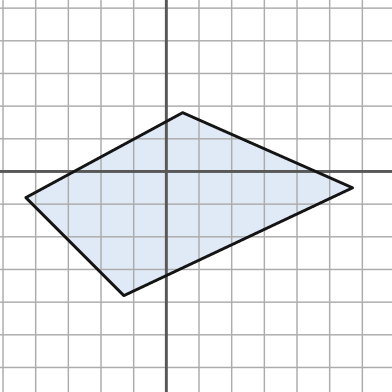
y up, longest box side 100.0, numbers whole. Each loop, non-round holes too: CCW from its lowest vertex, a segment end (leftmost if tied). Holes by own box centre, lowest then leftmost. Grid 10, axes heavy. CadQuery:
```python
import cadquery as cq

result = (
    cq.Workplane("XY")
    .moveTo(-13.0, -38.0)
    .lineTo(57.0, -5.0)
    .lineTo(5.0, 18.0)
    .lineTo(-43.0, -8.0)
    .close()
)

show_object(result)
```